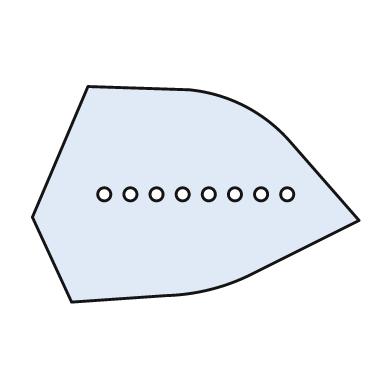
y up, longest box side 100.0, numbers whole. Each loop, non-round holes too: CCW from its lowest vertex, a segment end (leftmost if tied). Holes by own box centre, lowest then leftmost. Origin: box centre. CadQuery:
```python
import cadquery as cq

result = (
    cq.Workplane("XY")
    .moveTo(-38.0, -33.0)
    .lineTo(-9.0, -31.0)
    .threePointArc((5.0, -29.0), (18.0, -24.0))
    .lineTo(50.0, -8.0)
    .lineTo(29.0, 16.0)
    .threePointArc((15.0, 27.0), (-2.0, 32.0))
    .lineTo(-33.0, 33.0)
    .lineTo(-50.0, -7.0)
    .close()
    .moveTo(-28.0, 0.0)
    .circle(2.0)
    .moveTo(-20.0, 0.0)
    .circle(2.0)
    .moveTo(-12.0, 0.0)
    .circle(2.0)
    .moveTo(-4.0, 0.0)
    .circle(2.0)
    .moveTo(4.0, 0.0)
    .circle(2.0)
    .moveTo(12.0, 0.0)
    .circle(2.0)
    .moveTo(20.0, 0.0)
    .circle(2.0)
    .moveTo(28.0, 0.0)
    .circle(2.0)
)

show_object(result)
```